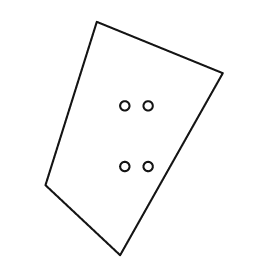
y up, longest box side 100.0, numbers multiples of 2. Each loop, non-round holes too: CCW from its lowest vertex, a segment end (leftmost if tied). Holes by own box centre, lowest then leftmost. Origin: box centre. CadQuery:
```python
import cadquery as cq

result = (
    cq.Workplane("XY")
    .moveTo(-6.0, -50.0)
    .lineTo(38.0, 28.0)
    .lineTo(-16.0, 50.0)
    .lineTo(-38.0, -20.0)
    .close()
    .moveTo(-4.0, -12.0)
    .circle(2.0)
    .moveTo(6.0, -12.0)
    .circle(2.0)
    .moveTo(-4.0, 14.0)
    .circle(2.0)
    .moveTo(6.0, 14.0)
    .circle(2.0)
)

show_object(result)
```